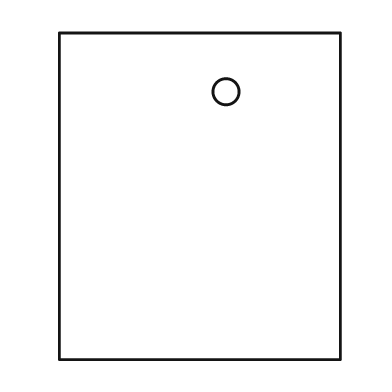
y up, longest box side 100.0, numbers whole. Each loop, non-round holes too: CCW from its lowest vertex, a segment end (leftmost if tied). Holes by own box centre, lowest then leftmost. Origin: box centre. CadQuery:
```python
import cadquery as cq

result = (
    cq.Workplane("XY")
    .moveTo(-43.0, -50.0)
    .lineTo(43.0, -50.0)
    .lineTo(43.0, 50.0)
    .lineTo(-43.0, 50.0)
    .close()
    .moveTo(8.0, 32.0)
    .circle(4.0)
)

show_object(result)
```